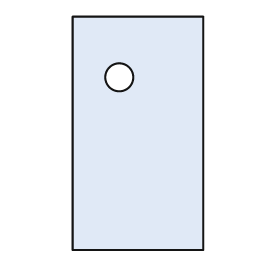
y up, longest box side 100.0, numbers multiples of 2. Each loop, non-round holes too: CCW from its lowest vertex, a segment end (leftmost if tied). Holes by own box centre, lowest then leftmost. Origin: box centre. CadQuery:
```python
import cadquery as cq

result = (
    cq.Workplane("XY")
    .moveTo(-28.0, -50.0)
    .lineTo(28.0, -50.0)
    .lineTo(28.0, 50.0)
    .lineTo(-28.0, 50.0)
    .close()
    .moveTo(-8.0, 24.0)
    .circle(6.0)
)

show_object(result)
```